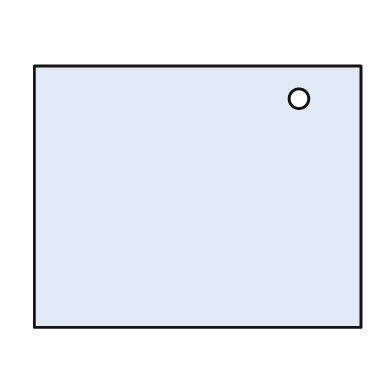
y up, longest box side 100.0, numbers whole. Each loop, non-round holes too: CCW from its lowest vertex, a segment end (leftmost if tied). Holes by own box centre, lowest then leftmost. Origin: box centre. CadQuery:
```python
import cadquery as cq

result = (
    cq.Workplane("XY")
    .moveTo(-50.0, -40.0)
    .lineTo(50.0, -40.0)
    .lineTo(50.0, 40.0)
    .lineTo(-50.0, 40.0)
    .close()
    .moveTo(31.0, 30.0)
    .circle(3.0)
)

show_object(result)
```